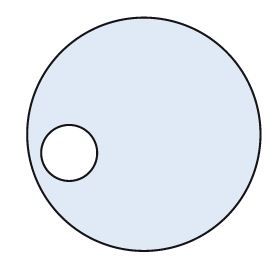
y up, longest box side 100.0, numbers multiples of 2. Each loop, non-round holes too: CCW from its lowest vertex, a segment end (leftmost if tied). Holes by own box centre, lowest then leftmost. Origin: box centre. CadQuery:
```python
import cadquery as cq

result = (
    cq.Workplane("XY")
    .moveTo(0.0, 0.0)
    .circle(50.0)
    .moveTo(-32.0, -8.0)
    .circle(12.0)
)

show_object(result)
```